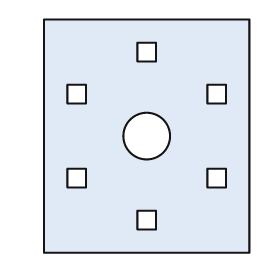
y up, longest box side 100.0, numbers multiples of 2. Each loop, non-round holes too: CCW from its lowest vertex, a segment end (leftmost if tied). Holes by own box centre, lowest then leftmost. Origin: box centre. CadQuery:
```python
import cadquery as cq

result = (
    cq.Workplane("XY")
    .moveTo(-44.0, -50.0)
    .lineTo(44.0, -50.0)
    .lineTo(44.0, 50.0)
    .lineTo(-44.0, 50.0)
    .close()
    .moveTo(-4.0, -40.0)
    .lineTo(4.0, -40.0)
    .lineTo(4.0, -32.0)
    .lineTo(-4.0, -32.0)
    .close()
    .moveTo(-34.0, -22.0)
    .lineTo(-26.0, -22.0)
    .lineTo(-26.0, -14.0)
    .lineTo(-34.0, -14.0)
    .close()
    .moveTo(26.0, -22.0)
    .lineTo(34.0, -22.0)
    .lineTo(34.0, -14.0)
    .lineTo(26.0, -14.0)
    .close()
    .moveTo(0.0, 0.0)
    .circle(10.0)
    .moveTo(-34.0, 14.0)
    .lineTo(-26.0, 14.0)
    .lineTo(-26.0, 22.0)
    .lineTo(-34.0, 22.0)
    .close()
    .moveTo(26.0, 14.0)
    .lineTo(34.0, 14.0)
    .lineTo(34.0, 22.0)
    .lineTo(26.0, 22.0)
    .close()
    .moveTo(-4.0, 32.0)
    .lineTo(4.0, 32.0)
    .lineTo(4.0, 40.0)
    .lineTo(-4.0, 40.0)
    .close()
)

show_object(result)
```